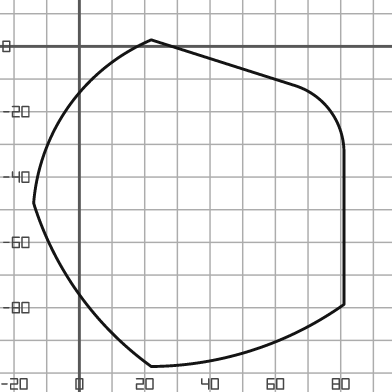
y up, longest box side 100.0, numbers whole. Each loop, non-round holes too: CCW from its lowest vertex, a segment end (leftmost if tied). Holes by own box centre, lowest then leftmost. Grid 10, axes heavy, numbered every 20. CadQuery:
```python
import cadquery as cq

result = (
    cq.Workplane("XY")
    .moveTo(22.0, -98.0)
    .threePointArc((53.0, -93.0), (81.0, -79.0))
    .lineTo(81.0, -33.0)
    .threePointArc((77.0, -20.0), (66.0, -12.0))
    .lineTo(22.0, 2.0)
    .threePointArc((-3.0, -18.0), (-14.0, -48.0))
    .threePointArc((0.0, -76.0), (22.0, -98.0))
    .close()
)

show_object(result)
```